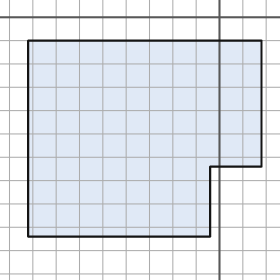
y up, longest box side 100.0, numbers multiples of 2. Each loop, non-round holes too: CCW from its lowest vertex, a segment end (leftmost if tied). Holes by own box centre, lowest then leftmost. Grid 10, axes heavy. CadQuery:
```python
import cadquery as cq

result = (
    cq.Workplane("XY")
    .moveTo(-82.0, -94.0)
    .lineTo(-4.0, -94.0)
    .lineTo(-4.0, -64.0)
    .lineTo(18.0, -64.0)
    .lineTo(18.0, -10.0)
    .lineTo(-82.0, -10.0)
    .close()
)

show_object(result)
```